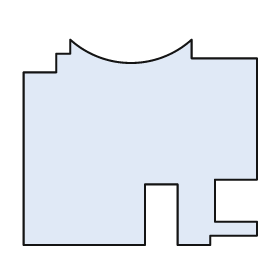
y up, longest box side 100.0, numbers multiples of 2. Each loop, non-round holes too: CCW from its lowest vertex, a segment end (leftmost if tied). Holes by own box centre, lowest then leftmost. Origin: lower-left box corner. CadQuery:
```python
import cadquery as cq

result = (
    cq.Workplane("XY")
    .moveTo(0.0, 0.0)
    .lineTo(52.0, 0.0)
    .lineTo(52.0, 26.0)
    .lineTo(66.0, 26.0)
    .lineTo(66.0, 0.0)
    .lineTo(80.0, 0.0)
    .lineTo(80.0, 4.0)
    .lineTo(100.0, 4.0)
    .lineTo(100.0, 10.0)
    .lineTo(82.0, 10.0)
    .lineTo(82.0, 28.0)
    .lineTo(100.0, 28.0)
    .lineTo(100.0, 80.0)
    .lineTo(72.0, 80.0)
    .lineTo(72.0, 88.0)
    .threePointArc((46.0, 78.0), (20.0, 88.0))
    .lineTo(20.0, 82.0)
    .lineTo(14.0, 82.0)
    .lineTo(14.0, 74.0)
    .lineTo(0.0, 74.0)
    .close()
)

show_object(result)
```